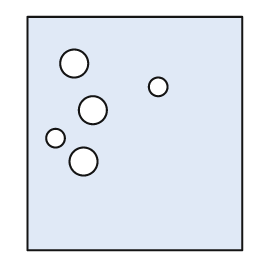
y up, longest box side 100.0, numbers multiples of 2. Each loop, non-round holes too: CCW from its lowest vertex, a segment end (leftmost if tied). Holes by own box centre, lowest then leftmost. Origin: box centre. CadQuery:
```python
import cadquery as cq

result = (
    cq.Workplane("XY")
    .moveTo(-46.0, -50.0)
    .lineTo(46.0, -50.0)
    .lineTo(46.0, 50.0)
    .lineTo(-46.0, 50.0)
    .close()
    .moveTo(-22.0, -12.0)
    .circle(6.0)
    .moveTo(-34.0, -2.0)
    .circle(4.0)
    .moveTo(-18.0, 10.0)
    .circle(6.0)
    .moveTo(10.0, 20.0)
    .circle(4.0)
    .moveTo(-26.0, 30.0)
    .circle(6.0)
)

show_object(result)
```